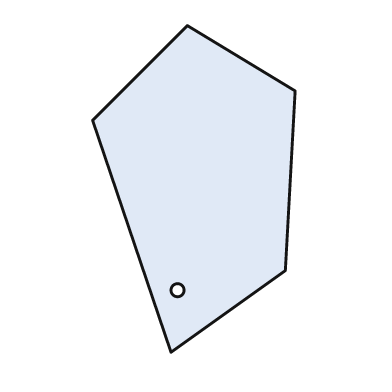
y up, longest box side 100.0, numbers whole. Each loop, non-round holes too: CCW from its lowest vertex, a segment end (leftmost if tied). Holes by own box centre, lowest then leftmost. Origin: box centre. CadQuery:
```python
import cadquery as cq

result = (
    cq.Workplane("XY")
    .moveTo(-7.0, -50.0)
    .lineTo(28.0, -25.0)
    .lineTo(31.0, 30.0)
    .lineTo(-2.0, 50.0)
    .lineTo(-31.0, 21.0)
    .close()
    .moveTo(-5.0, -31.0)
    .circle(2.0)
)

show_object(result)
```